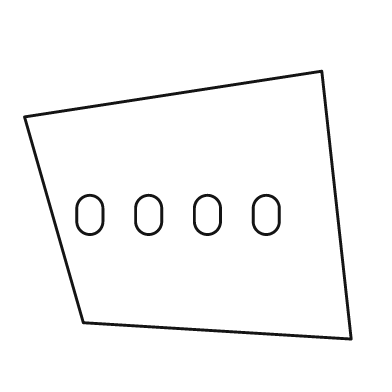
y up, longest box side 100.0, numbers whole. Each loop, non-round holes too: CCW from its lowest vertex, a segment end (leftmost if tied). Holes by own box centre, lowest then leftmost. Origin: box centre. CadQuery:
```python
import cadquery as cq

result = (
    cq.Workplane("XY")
    .moveTo(50.0, -41.0)
    .lineTo(41.0, 41.0)
    .lineTo(-50.0, 27.0)
    .lineTo(-32.0, -36.0)
    .close()
    .moveTo(-34.0, -5.0)
    .threePointArc((-30.0, -9.0), (-26.0, -5.0))
    .lineTo(-26.0, -1.0)
    .threePointArc((-30.0, 3.0), (-34.0, -1.0))
    .close()
    .moveTo(-16.0, -5.0)
    .threePointArc((-12.0, -9.0), (-8.0, -5.0))
    .lineTo(-8.0, -1.0)
    .threePointArc((-12.0, 3.0), (-16.0, -1.0))
    .close()
    .moveTo(2.0, -5.0)
    .threePointArc((6.0, -9.0), (10.0, -5.0))
    .lineTo(10.0, -1.0)
    .threePointArc((6.0, 3.0), (2.0, -1.0))
    .close()
    .moveTo(20.0, -5.0)
    .threePointArc((24.0, -9.0), (28.0, -5.0))
    .lineTo(28.0, -1.0)
    .threePointArc((24.0, 3.0), (20.0, -1.0))
    .close()
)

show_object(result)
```